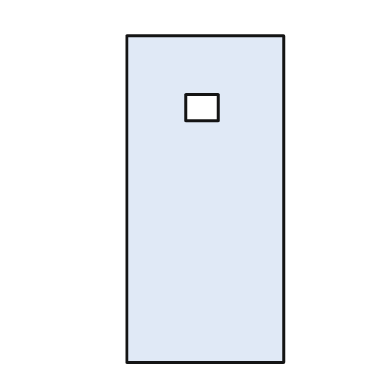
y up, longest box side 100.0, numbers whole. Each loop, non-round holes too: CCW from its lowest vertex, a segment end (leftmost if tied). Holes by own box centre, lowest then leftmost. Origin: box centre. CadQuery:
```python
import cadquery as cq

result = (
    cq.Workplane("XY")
    .moveTo(-24.0, -50.0)
    .lineTo(24.0, -50.0)
    .lineTo(24.0, 50.0)
    .lineTo(-24.0, 50.0)
    .close()
    .moveTo(-6.0, 24.0)
    .lineTo(4.0, 24.0)
    .lineTo(4.0, 32.0)
    .lineTo(-6.0, 32.0)
    .close()
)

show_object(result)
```